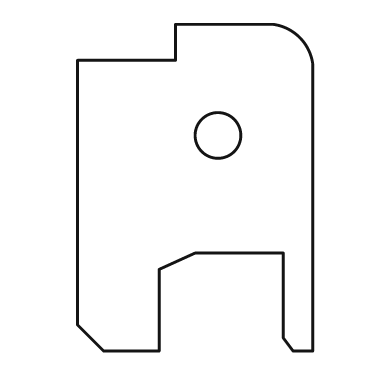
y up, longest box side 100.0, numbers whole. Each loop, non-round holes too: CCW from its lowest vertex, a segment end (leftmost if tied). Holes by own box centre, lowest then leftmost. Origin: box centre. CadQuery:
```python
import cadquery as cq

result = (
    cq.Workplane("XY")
    .moveTo(-28.0, -50.0)
    .lineTo(-11.0, -50.0)
    .lineTo(-11.0, -25.0)
    .lineTo(0.0, -20.0)
    .lineTo(27.0, -20.0)
    .lineTo(27.0, -46.0)
    .lineTo(30.0, -50.0)
    .lineTo(36.0, -50.0)
    .lineTo(36.0, 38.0)
    .threePointArc((32.0, 46.0), (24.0, 50.0))
    .lineTo(-6.0, 50.0)
    .lineTo(-6.0, 39.0)
    .lineTo(-36.0, 39.0)
    .lineTo(-36.0, -42.0)
    .close()
    .moveTo(7.0, 16.0)
    .circle(7.0)
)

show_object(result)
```